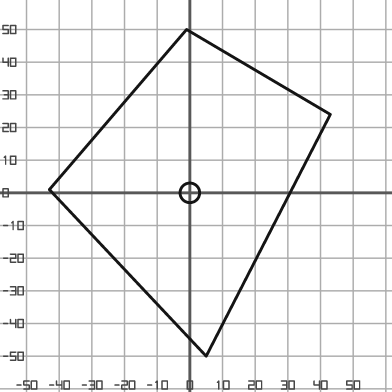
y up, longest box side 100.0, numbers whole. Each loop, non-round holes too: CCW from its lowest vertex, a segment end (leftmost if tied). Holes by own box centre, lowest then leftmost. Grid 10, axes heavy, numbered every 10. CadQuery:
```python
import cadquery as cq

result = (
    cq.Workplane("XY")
    .moveTo(5.0, -50.0)
    .lineTo(43.0, 24.0)
    .lineTo(-1.0, 50.0)
    .lineTo(-43.0, 1.0)
    .close()
    .moveTo(0.0, 0.0)
    .circle(3.0)
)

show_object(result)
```